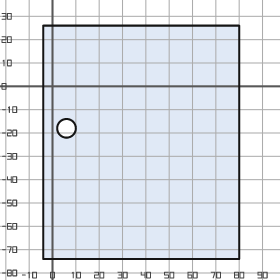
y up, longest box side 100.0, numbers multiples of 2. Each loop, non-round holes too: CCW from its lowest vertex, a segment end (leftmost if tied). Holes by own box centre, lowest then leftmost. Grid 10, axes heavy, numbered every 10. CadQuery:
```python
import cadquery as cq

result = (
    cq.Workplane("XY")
    .moveTo(-4.0, -74.0)
    .lineTo(80.0, -74.0)
    .lineTo(80.0, 26.0)
    .lineTo(-4.0, 26.0)
    .close()
    .moveTo(6.0, -18.0)
    .circle(4.0)
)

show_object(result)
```